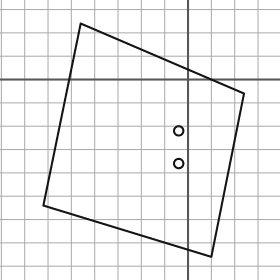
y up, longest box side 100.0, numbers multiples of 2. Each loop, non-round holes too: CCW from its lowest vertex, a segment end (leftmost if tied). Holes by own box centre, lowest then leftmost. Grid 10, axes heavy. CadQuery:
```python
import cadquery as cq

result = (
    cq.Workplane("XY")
    .moveTo(10.0, -76.0)
    .lineTo(24.0, -6.0)
    .lineTo(-46.0, 24.0)
    .lineTo(-62.0, -54.0)
    .close()
    .moveTo(-4.0, -36.0)
    .circle(2.0)
    .moveTo(-4.0, -22.0)
    .circle(2.0)
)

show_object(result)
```